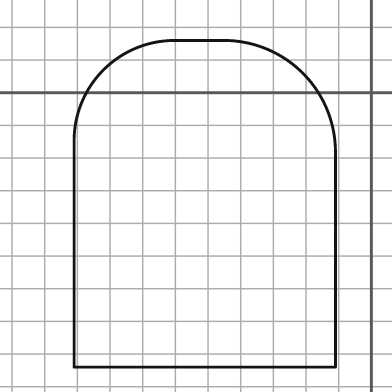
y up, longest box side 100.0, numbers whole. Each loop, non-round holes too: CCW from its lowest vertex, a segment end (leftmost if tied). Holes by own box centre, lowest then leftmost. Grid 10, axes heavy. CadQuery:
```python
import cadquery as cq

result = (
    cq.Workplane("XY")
    .moveTo(-91.0, -84.0)
    .lineTo(-11.0, -84.0)
    .lineTo(-11.0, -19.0)
    .threePointArc((-21.0, 6.0), (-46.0, 16.0))
    .lineTo(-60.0, 16.0)
    .threePointArc((-82.0, 7.0), (-91.0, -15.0))
    .close()
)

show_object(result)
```